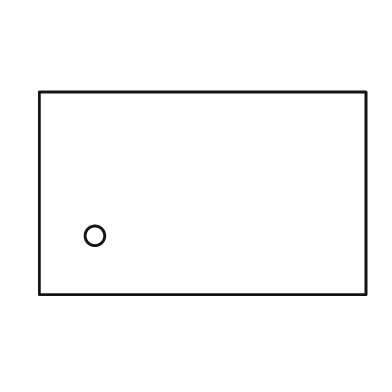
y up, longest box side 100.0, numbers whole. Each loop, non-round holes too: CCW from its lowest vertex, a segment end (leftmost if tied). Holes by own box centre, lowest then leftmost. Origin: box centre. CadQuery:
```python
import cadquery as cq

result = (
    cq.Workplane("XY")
    .moveTo(-50.0, -31.0)
    .lineTo(50.0, -31.0)
    .lineTo(50.0, 31.0)
    .lineTo(-50.0, 31.0)
    .close()
    .moveTo(-33.0, -13.0)
    .circle(3.0)
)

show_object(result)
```